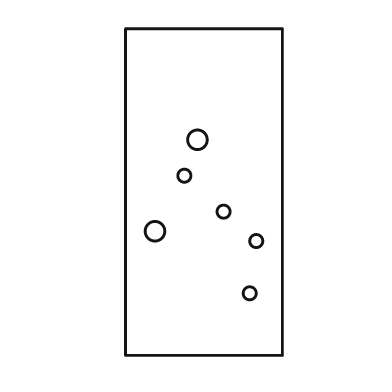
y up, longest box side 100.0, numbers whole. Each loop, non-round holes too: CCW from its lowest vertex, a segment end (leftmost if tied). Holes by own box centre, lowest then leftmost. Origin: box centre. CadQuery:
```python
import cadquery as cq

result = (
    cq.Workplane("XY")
    .moveTo(-24.0, -50.0)
    .lineTo(24.0, -50.0)
    .lineTo(24.0, 50.0)
    .lineTo(-24.0, 50.0)
    .close()
    .moveTo(14.0, -31.0)
    .circle(2.0)
    .moveTo(16.0, -15.0)
    .circle(2.0)
    .moveTo(-15.0, -12.0)
    .circle(3.0)
    .moveTo(6.0, -6.0)
    .circle(2.0)
    .moveTo(-6.0, 5.0)
    .circle(2.0)
    .moveTo(-2.0, 16.0)
    .circle(3.0)
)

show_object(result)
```